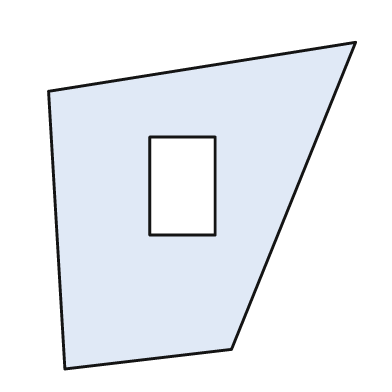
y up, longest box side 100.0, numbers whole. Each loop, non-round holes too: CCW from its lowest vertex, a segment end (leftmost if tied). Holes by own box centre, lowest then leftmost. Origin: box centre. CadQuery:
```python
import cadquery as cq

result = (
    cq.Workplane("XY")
    .moveTo(-42.0, -50.0)
    .lineTo(9.0, -44.0)
    .lineTo(47.0, 50.0)
    .lineTo(-47.0, 35.0)
    .close()
    .moveTo(-16.0, -9.0)
    .lineTo(4.0, -9.0)
    .lineTo(4.0, 21.0)
    .lineTo(-16.0, 21.0)
    .close()
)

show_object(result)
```